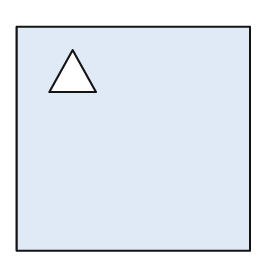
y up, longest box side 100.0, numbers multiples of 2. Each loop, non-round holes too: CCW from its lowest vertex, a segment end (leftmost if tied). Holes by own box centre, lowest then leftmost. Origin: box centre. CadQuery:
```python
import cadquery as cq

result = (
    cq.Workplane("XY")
    .moveTo(-50.0, -48.0)
    .lineTo(50.0, -48.0)
    .lineTo(50.0, 48.0)
    .lineTo(-50.0, 48.0)
    .close()
    .moveTo(-36.0, 20.0)
    .lineTo(-16.0, 20.0)
    .lineTo(-26.0, 38.0)
    .close()
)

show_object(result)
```